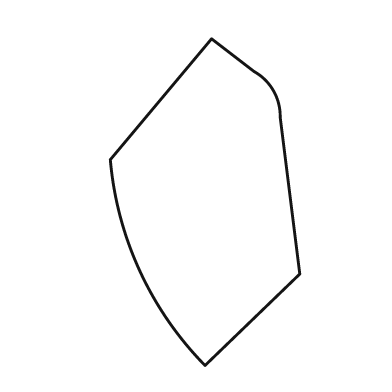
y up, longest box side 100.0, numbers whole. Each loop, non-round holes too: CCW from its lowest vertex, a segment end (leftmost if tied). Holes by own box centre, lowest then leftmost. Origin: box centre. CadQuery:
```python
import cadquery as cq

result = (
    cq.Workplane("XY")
    .moveTo(0.0, -50.0)
    .lineTo(29.0, -22.0)
    .lineTo(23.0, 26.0)
    .threePointArc((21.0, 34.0), (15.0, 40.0))
    .lineTo(2.0, 50.0)
    .lineTo(-29.0, 13.0)
    .threePointArc((-20.0, -21.0), (0.0, -50.0))
    .close()
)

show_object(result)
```